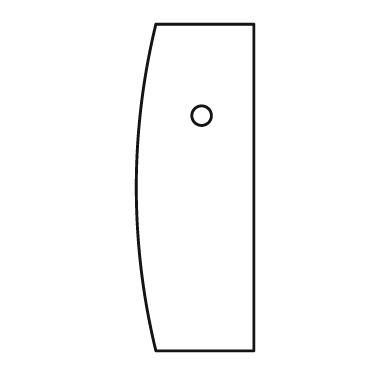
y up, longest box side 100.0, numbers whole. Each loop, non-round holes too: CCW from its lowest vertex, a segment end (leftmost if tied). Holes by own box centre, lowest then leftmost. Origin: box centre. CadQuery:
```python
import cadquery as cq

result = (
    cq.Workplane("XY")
    .moveTo(-12.0, -50.0)
    .lineTo(18.0, -50.0)
    .lineTo(18.0, 50.0)
    .lineTo(-12.0, 50.0)
    .threePointArc((-18.0, 0.0), (-12.0, -50.0))
    .close()
    .moveTo(2.0, 22.0)
    .circle(3.0)
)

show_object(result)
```